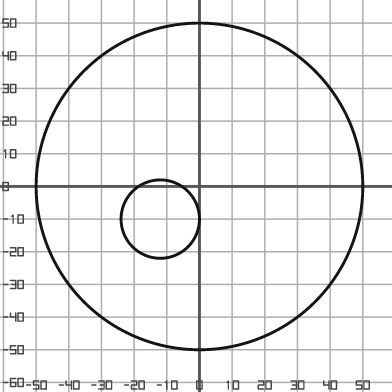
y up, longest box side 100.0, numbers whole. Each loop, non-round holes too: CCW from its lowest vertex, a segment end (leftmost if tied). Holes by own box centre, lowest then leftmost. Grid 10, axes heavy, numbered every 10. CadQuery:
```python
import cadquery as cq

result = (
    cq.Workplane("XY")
    .moveTo(0.0, 0.0)
    .circle(50.0)
    .moveTo(-12.0, -10.0)
    .circle(12.0)
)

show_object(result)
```